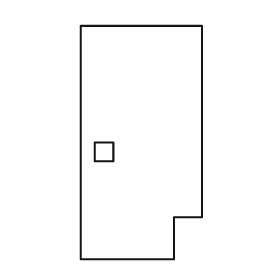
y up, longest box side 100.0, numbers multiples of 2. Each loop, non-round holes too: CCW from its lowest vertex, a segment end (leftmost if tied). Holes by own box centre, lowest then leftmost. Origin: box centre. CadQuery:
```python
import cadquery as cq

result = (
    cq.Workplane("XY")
    .moveTo(-26.0, -50.0)
    .lineTo(14.0, -50.0)
    .lineTo(14.0, -32.0)
    .lineTo(26.0, -32.0)
    .lineTo(26.0, 50.0)
    .lineTo(-26.0, 50.0)
    .close()
    .moveTo(-20.0, -8.0)
    .lineTo(-12.0, -8.0)
    .lineTo(-12.0, 0.0)
    .lineTo(-20.0, 0.0)
    .close()
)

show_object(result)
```